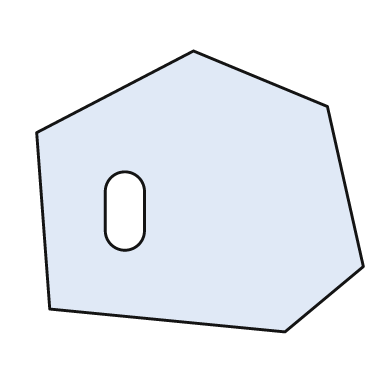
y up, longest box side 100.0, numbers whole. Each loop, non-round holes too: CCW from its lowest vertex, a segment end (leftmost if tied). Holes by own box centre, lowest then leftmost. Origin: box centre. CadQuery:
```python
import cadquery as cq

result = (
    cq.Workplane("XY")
    .moveTo(26.0, -43.0)
    .lineTo(50.0, -23.0)
    .lineTo(39.0, 26.0)
    .lineTo(-2.0, 43.0)
    .lineTo(-50.0, 18.0)
    .lineTo(-46.0, -36.0)
    .close()
    .moveTo(-29.0, -12.0)
    .threePointArc((-23.0, -18.0), (-17.0, -12.0))
    .lineTo(-17.0, 0.0)
    .threePointArc((-23.0, 6.0), (-29.0, 0.0))
    .close()
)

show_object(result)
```